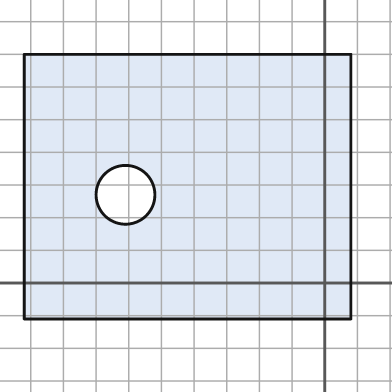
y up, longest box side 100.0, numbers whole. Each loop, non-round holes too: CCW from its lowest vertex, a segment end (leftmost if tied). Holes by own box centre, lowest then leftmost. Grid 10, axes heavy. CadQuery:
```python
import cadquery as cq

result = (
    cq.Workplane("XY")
    .moveTo(-92.0, -11.0)
    .lineTo(8.0, -11.0)
    .lineTo(8.0, 70.0)
    .lineTo(-92.0, 70.0)
    .close()
    .moveTo(-61.0, 27.0)
    .circle(9.0)
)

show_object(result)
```